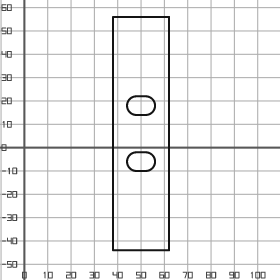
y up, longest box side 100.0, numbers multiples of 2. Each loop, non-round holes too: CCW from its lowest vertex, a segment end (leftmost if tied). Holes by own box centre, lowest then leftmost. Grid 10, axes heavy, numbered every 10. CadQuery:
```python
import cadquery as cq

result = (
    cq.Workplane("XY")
    .moveTo(38.0, -44.0)
    .lineTo(62.0, -44.0)
    .lineTo(62.0, 56.0)
    .lineTo(38.0, 56.0)
    .close()
    .moveTo(48.0, -10.0)
    .lineTo(52.0, -10.0)
    .threePointArc((56.0, -6.0), (52.0, -2.0))
    .lineTo(48.0, -2.0)
    .threePointArc((44.0, -6.0), (48.0, -10.0))
    .close()
    .moveTo(48.0, 14.0)
    .lineTo(52.0, 14.0)
    .threePointArc((56.0, 18.0), (52.0, 22.0))
    .lineTo(48.0, 22.0)
    .threePointArc((44.0, 18.0), (48.0, 14.0))
    .close()
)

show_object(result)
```